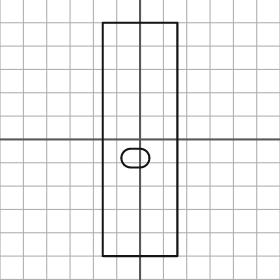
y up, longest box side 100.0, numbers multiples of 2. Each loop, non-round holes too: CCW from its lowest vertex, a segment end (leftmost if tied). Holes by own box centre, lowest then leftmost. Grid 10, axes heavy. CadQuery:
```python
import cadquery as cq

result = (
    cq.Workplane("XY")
    .moveTo(-16.0, -50.0)
    .lineTo(16.0, -50.0)
    .lineTo(16.0, 50.0)
    .lineTo(-16.0, 50.0)
    .close()
    .moveTo(-4.0, -12.0)
    .lineTo(0.0, -12.0)
    .threePointArc((4.0, -8.0), (0.0, -4.0))
    .lineTo(-4.0, -4.0)
    .threePointArc((-8.0, -8.0), (-4.0, -12.0))
    .close()
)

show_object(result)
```